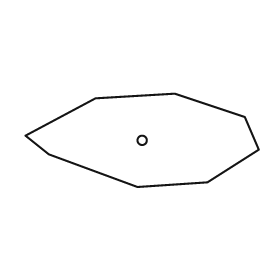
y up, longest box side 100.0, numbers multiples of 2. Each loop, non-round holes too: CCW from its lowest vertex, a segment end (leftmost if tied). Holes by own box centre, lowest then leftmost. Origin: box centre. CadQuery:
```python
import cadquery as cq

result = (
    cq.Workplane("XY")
    .moveTo(-2.0, -20.0)
    .lineTo(28.0, -18.0)
    .lineTo(50.0, -4.0)
    .lineTo(44.0, 10.0)
    .lineTo(14.0, 20.0)
    .lineTo(-20.0, 18.0)
    .lineTo(-50.0, 2.0)
    .lineTo(-40.0, -6.0)
    .close()
    .moveTo(0.0, 0.0)
    .circle(2.0)
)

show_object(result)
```